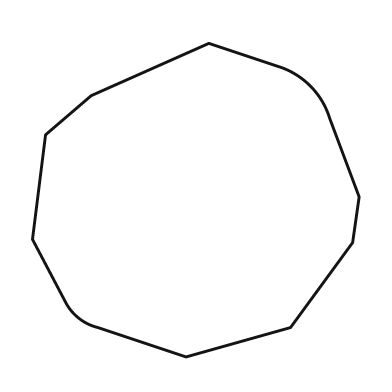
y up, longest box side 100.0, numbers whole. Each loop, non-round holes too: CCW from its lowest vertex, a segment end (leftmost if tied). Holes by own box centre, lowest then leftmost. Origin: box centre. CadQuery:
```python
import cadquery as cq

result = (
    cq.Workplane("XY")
    .moveTo(-3.0, -48.0)
    .lineTo(29.0, -39.0)
    .lineTo(48.0, -13.0)
    .lineTo(50.0, 1.0)
    .lineTo(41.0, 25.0)
    .threePointArc((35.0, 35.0), (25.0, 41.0))
    .lineTo(4.0, 48.0)
    .lineTo(-32.0, 32.0)
    .lineTo(-46.0, 20.0)
    .lineTo(-50.0, -12.0)
    .lineTo(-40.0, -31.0)
    .threePointArc((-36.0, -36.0), (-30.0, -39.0))
    .close()
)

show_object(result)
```